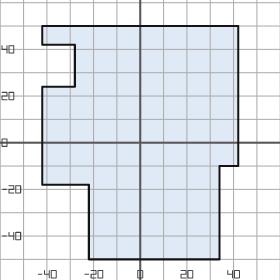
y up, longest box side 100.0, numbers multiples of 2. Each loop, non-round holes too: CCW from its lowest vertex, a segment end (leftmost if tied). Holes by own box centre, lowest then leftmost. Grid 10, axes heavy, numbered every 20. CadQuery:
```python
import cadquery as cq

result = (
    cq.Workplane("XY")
    .moveTo(-22.0, -50.0)
    .lineTo(34.0, -50.0)
    .lineTo(34.0, -10.0)
    .lineTo(42.0, -10.0)
    .lineTo(42.0, 50.0)
    .lineTo(-42.0, 50.0)
    .lineTo(-42.0, 42.0)
    .lineTo(-28.0, 42.0)
    .lineTo(-28.0, 24.0)
    .lineTo(-42.0, 24.0)
    .lineTo(-42.0, -18.0)
    .lineTo(-22.0, -18.0)
    .close()
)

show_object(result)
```